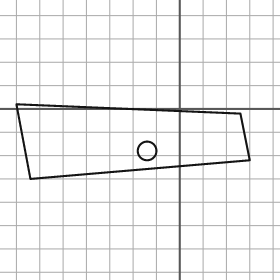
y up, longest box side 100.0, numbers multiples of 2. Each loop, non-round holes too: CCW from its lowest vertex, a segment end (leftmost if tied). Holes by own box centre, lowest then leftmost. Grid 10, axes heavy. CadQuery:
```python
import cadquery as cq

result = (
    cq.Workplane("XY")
    .moveTo(-64.0, -30.0)
    .lineTo(30.0, -22.0)
    .lineTo(26.0, -2.0)
    .lineTo(-70.0, 2.0)
    .close()
    .moveTo(-14.0, -18.0)
    .circle(4.0)
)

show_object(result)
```